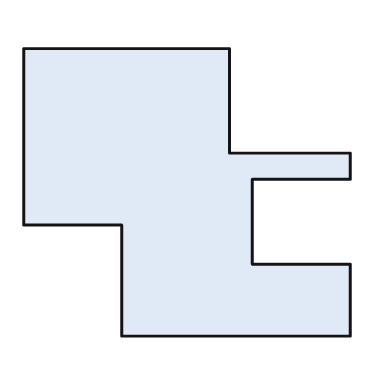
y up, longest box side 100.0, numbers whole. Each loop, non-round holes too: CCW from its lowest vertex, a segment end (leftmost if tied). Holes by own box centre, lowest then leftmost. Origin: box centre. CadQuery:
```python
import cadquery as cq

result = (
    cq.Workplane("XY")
    .moveTo(-20.0, -44.0)
    .lineTo(50.0, -44.0)
    .lineTo(50.0, -22.0)
    .lineTo(20.0, -22.0)
    .lineTo(20.0, 4.0)
    .lineTo(50.0, 4.0)
    .lineTo(50.0, 12.0)
    .lineTo(13.0, 12.0)
    .lineTo(13.0, 44.0)
    .lineTo(-50.0, 44.0)
    .lineTo(-50.0, -10.0)
    .lineTo(-20.0, -10.0)
    .close()
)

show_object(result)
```